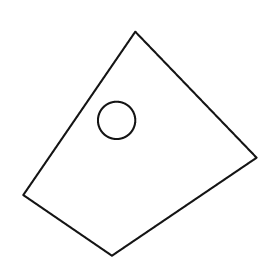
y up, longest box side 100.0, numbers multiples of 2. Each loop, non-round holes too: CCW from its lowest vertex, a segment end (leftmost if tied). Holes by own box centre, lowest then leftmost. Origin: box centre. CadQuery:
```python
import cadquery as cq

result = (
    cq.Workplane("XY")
    .moveTo(-12.0, -48.0)
    .lineTo(50.0, -6.0)
    .lineTo(-2.0, 48.0)
    .lineTo(-50.0, -22.0)
    .close()
    .moveTo(-10.0, 10.0)
    .circle(8.0)
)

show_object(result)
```